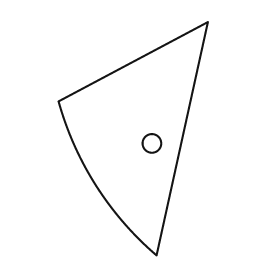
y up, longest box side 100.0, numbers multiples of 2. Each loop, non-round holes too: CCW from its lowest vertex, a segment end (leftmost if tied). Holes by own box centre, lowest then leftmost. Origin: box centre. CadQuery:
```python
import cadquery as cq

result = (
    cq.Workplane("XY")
    .moveTo(10.0, -50.0)
    .lineTo(32.0, 50.0)
    .lineTo(-32.0, 16.0)
    .threePointArc((-16.0, -20.0), (10.0, -50.0))
    .close()
    .moveTo(8.0, -2.0)
    .circle(4.0)
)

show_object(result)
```